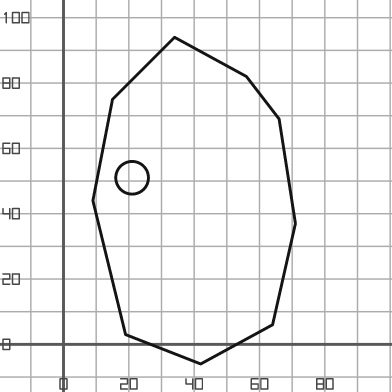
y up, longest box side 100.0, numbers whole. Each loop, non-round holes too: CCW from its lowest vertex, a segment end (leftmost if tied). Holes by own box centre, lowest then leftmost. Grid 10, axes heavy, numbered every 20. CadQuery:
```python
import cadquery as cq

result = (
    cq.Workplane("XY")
    .moveTo(42.0, -6.0)
    .lineTo(64.0, 6.0)
    .lineTo(71.0, 37.0)
    .lineTo(66.0, 69.0)
    .lineTo(56.0, 82.0)
    .lineTo(34.0, 94.0)
    .lineTo(15.0, 75.0)
    .lineTo(9.0, 44.0)
    .lineTo(19.0, 3.0)
    .close()
    .moveTo(21.0, 51.0)
    .circle(5.0)
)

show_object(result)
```